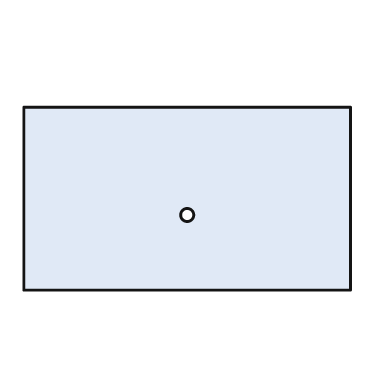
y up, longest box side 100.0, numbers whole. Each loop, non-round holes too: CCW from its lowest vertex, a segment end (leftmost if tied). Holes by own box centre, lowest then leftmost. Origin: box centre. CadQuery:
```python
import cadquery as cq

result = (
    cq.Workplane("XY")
    .moveTo(-50.0, -28.0)
    .lineTo(50.0, -28.0)
    .lineTo(50.0, 28.0)
    .lineTo(-50.0, 28.0)
    .close()
    .moveTo(0.0, -5.0)
    .circle(2.0)
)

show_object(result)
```